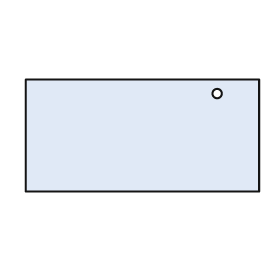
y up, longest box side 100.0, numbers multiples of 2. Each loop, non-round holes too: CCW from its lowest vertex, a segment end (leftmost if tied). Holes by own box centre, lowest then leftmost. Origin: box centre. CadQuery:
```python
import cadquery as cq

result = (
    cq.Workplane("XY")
    .moveTo(-50.0, -24.0)
    .lineTo(50.0, -24.0)
    .lineTo(50.0, 24.0)
    .lineTo(-50.0, 24.0)
    .close()
    .moveTo(32.0, 18.0)
    .circle(2.0)
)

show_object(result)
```